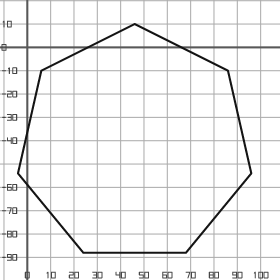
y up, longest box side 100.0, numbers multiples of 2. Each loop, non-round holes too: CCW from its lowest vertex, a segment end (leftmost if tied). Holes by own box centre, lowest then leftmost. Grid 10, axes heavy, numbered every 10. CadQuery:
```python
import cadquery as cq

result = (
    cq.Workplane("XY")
    .moveTo(24.0, -88.0)
    .lineTo(68.0, -88.0)
    .lineTo(96.0, -54.0)
    .lineTo(86.0, -10.0)
    .lineTo(46.0, 10.0)
    .lineTo(6.0, -10.0)
    .lineTo(-4.0, -54.0)
    .close()
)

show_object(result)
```